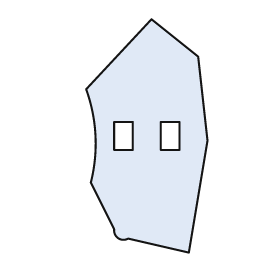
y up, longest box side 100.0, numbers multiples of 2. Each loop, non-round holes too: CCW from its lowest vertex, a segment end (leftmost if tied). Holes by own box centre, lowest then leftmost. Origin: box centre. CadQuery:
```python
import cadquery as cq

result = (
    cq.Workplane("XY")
    .moveTo(18.0, -50.0)
    .lineTo(26.0, -2.0)
    .lineTo(22.0, 34.0)
    .lineTo(2.0, 50.0)
    .lineTo(-26.0, 20.0)
    .threePointArc((-22.0, 0.0), (-24.0, -20.0))
    .lineTo(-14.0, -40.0)
    .threePointArc((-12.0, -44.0), (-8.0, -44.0))
    .close()
    .moveTo(-14.0, -6.0)
    .lineTo(-6.0, -6.0)
    .lineTo(-6.0, 6.0)
    .lineTo(-14.0, 6.0)
    .close()
    .moveTo(6.0, -6.0)
    .lineTo(14.0, -6.0)
    .lineTo(14.0, 6.0)
    .lineTo(6.0, 6.0)
    .close()
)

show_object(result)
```